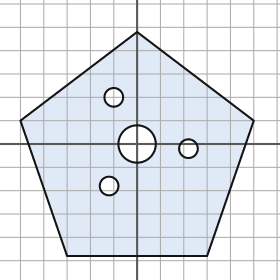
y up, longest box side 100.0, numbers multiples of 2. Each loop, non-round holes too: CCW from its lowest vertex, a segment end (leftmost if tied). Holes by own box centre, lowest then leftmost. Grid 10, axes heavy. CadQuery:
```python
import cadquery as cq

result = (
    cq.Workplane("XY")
    .moveTo(-30.0, -48.0)
    .lineTo(30.0, -48.0)
    .lineTo(50.0, 10.0)
    .lineTo(0.0, 48.0)
    .lineTo(-50.0, 10.0)
    .close()
    .moveTo(-12.0, -18.0)
    .circle(4.0)
    .moveTo(22.0, -2.0)
    .circle(4.0)
    .moveTo(0.0, 0.0)
    .circle(8.0)
    .moveTo(-10.0, 20.0)
    .circle(4.0)
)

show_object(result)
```